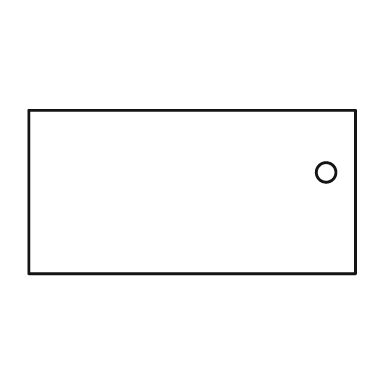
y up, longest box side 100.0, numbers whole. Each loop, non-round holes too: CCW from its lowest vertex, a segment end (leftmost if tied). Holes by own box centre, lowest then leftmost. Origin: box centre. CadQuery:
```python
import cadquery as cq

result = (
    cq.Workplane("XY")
    .moveTo(-50.0, -25.0)
    .lineTo(50.0, -25.0)
    .lineTo(50.0, 25.0)
    .lineTo(-50.0, 25.0)
    .close()
    .moveTo(41.0, 6.0)
    .circle(3.0)
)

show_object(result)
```